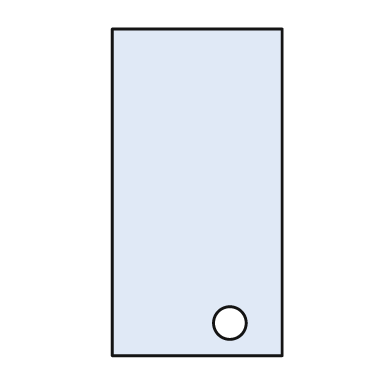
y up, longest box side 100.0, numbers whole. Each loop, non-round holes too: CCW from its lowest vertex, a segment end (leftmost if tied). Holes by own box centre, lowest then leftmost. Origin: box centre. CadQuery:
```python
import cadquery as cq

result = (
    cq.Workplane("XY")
    .moveTo(-26.0, -50.0)
    .lineTo(26.0, -50.0)
    .lineTo(26.0, 50.0)
    .lineTo(-26.0, 50.0)
    .close()
    .moveTo(10.0, -40.0)
    .circle(5.0)
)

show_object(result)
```